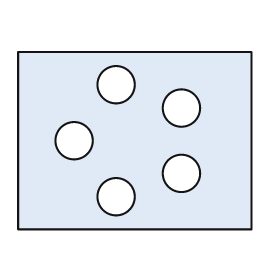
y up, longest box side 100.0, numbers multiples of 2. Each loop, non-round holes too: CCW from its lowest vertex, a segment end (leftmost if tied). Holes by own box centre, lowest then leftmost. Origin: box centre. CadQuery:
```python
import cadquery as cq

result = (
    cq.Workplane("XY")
    .moveTo(-50.0, -38.0)
    .lineTo(50.0, -38.0)
    .lineTo(50.0, 38.0)
    .lineTo(-50.0, 38.0)
    .close()
    .moveTo(-8.0, -24.0)
    .circle(8.0)
    .moveTo(20.0, -14.0)
    .circle(8.0)
    .moveTo(-26.0, 0.0)
    .circle(8.0)
    .moveTo(20.0, 14.0)
    .circle(8.0)
    .moveTo(-8.0, 24.0)
    .circle(8.0)
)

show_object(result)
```